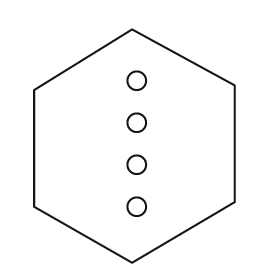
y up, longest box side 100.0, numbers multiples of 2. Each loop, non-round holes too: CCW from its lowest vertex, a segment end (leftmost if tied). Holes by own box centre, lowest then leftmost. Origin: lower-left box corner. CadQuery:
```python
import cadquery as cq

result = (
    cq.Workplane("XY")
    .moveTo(42.0, 0.0)
    .lineTo(86.0, 26.0)
    .lineTo(86.0, 76.0)
    .lineTo(42.0, 100.0)
    .lineTo(0.0, 74.0)
    .lineTo(0.0, 24.0)
    .close()
    .moveTo(44.0, 24.0)
    .circle(4.0)
    .moveTo(44.0, 42.0)
    .circle(4.0)
    .moveTo(44.0, 60.0)
    .circle(4.0)
    .moveTo(44.0, 78.0)
    .circle(4.0)
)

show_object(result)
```